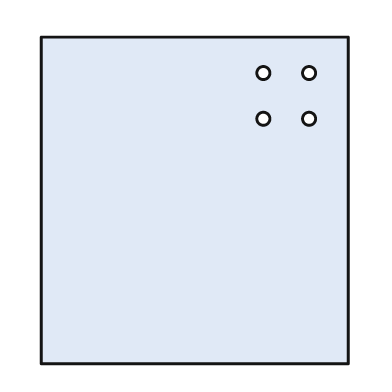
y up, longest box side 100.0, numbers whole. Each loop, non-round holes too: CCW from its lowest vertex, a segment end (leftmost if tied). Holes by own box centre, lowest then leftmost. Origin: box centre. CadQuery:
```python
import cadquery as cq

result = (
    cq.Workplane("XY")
    .moveTo(-47.0, -50.0)
    .lineTo(47.0, -50.0)
    .lineTo(47.0, 50.0)
    .lineTo(-47.0, 50.0)
    .close()
    .moveTo(21.0, 25.0)
    .circle(2.0)
    .moveTo(35.0, 25.0)
    .circle(2.0)
    .moveTo(21.0, 39.0)
    .circle(2.0)
    .moveTo(35.0, 39.0)
    .circle(2.0)
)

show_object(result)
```